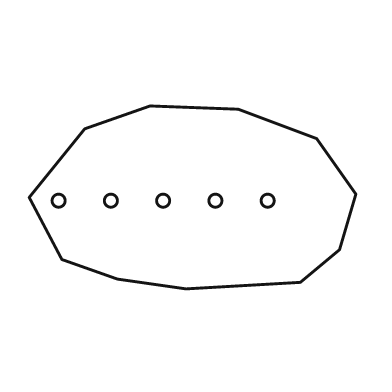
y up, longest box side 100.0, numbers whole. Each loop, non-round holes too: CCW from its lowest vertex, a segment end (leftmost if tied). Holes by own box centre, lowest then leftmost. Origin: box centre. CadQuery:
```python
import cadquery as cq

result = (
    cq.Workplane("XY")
    .moveTo(-2.0, -28.0)
    .lineTo(33.0, -26.0)
    .lineTo(45.0, -16.0)
    .lineTo(50.0, 1.0)
    .lineTo(38.0, 18.0)
    .lineTo(14.0, 27.0)
    .lineTo(-13.0, 28.0)
    .lineTo(-33.0, 21.0)
    .lineTo(-50.0, 0.0)
    .lineTo(-40.0, -19.0)
    .lineTo(-23.0, -25.0)
    .close()
    .moveTo(-41.0, -1.0)
    .circle(2.0)
    .moveTo(-25.0, -1.0)
    .circle(2.0)
    .moveTo(-9.0, -1.0)
    .circle(2.0)
    .moveTo(7.0, -1.0)
    .circle(2.0)
    .moveTo(23.0, -1.0)
    .circle(2.0)
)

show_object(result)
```